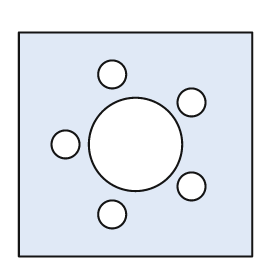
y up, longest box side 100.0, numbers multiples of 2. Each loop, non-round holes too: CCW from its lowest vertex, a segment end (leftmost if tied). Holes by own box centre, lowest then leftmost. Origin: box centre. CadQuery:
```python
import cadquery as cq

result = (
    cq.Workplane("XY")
    .moveTo(-50.0, -48.0)
    .lineTo(50.0, -48.0)
    .lineTo(50.0, 48.0)
    .lineTo(-50.0, 48.0)
    .close()
    .moveTo(-10.0, -30.0)
    .circle(6.0)
    .moveTo(24.0, -18.0)
    .circle(6.0)
    .moveTo(-30.0, 0.0)
    .circle(6.0)
    .moveTo(0.0, 0.0)
    .circle(20.0)
    .moveTo(24.0, 18.0)
    .circle(6.0)
    .moveTo(-10.0, 30.0)
    .circle(6.0)
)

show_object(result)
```